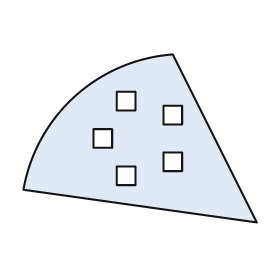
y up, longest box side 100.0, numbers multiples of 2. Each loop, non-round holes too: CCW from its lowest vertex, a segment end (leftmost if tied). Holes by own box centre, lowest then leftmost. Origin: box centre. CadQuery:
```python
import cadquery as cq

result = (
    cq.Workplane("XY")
    .moveTo(50.0, -36.0)
    .lineTo(14.0, 36.0)
    .threePointArc((-28.0, 18.0), (-50.0, -22.0))
    .close()
    .moveTo(-10.0, -20.0)
    .lineTo(-2.0, -20.0)
    .lineTo(-2.0, -12.0)
    .lineTo(-10.0, -12.0)
    .close()
    .moveTo(10.0, -14.0)
    .lineTo(18.0, -14.0)
    .lineTo(18.0, -6.0)
    .lineTo(10.0, -6.0)
    .close()
    .moveTo(-20.0, -4.0)
    .lineTo(-12.0, -4.0)
    .lineTo(-12.0, 4.0)
    .lineTo(-20.0, 4.0)
    .close()
    .moveTo(10.0, 6.0)
    .lineTo(18.0, 6.0)
    .lineTo(18.0, 14.0)
    .lineTo(10.0, 14.0)
    .close()
    .moveTo(-10.0, 12.0)
    .lineTo(-2.0, 12.0)
    .lineTo(-2.0, 20.0)
    .lineTo(-10.0, 20.0)
    .close()
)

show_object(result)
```